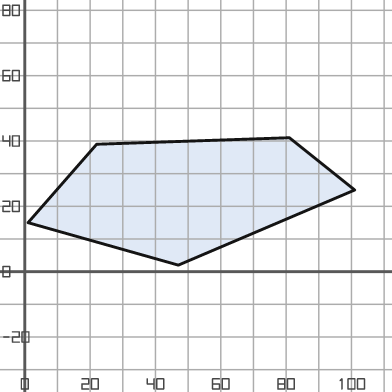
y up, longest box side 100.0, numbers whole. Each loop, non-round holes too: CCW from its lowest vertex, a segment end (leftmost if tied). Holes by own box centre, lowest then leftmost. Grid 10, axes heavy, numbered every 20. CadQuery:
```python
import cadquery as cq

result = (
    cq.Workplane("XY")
    .moveTo(47.0, 2.0)
    .lineTo(101.0, 25.0)
    .lineTo(81.0, 41.0)
    .lineTo(22.0, 39.0)
    .lineTo(1.0, 15.0)
    .close()
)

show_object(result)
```